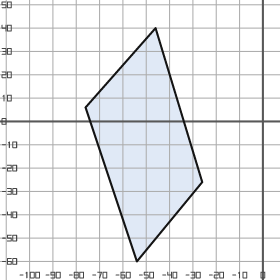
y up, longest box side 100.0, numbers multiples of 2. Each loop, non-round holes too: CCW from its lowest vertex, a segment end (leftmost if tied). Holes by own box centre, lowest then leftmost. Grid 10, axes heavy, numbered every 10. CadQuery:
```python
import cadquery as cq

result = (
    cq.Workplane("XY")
    .moveTo(-54.0, -60.0)
    .lineTo(-26.0, -26.0)
    .lineTo(-46.0, 40.0)
    .lineTo(-76.0, 6.0)
    .close()
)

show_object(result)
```